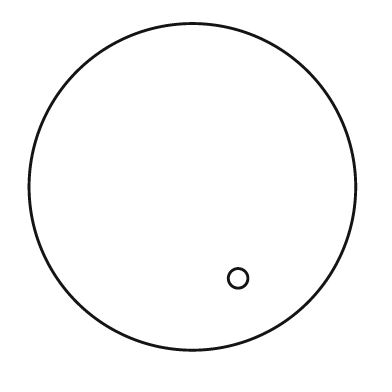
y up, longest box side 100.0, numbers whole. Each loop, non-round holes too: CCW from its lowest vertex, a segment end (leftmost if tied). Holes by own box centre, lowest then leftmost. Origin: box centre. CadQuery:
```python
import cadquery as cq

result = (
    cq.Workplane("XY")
    .moveTo(0.0, 0.0)
    .circle(50.0)
    .moveTo(14.0, -28.0)
    .circle(3.0)
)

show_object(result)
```